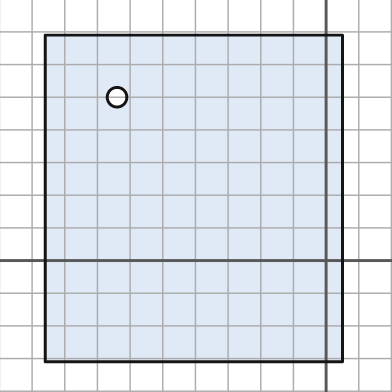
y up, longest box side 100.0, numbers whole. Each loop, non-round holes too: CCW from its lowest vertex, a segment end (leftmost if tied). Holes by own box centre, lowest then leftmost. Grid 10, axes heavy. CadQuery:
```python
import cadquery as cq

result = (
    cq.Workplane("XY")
    .moveTo(-86.0, -31.0)
    .lineTo(5.0, -31.0)
    .lineTo(5.0, 69.0)
    .lineTo(-86.0, 69.0)
    .close()
    .moveTo(-64.0, 50.0)
    .circle(3.0)
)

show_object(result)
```